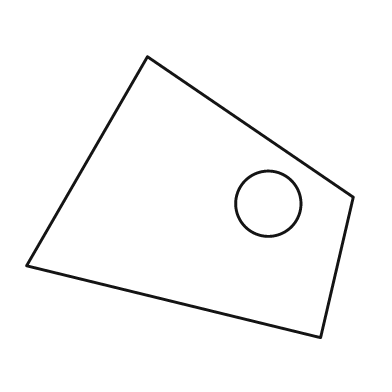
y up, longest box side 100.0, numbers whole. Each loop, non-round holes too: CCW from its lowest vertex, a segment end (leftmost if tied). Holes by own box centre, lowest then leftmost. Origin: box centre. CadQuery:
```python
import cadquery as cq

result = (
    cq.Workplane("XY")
    .moveTo(40.0, -43.0)
    .lineTo(50.0, 0.0)
    .lineTo(-13.0, 43.0)
    .lineTo(-50.0, -21.0)
    .close()
    .moveTo(24.0, -2.0)
    .circle(10.0)
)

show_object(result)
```